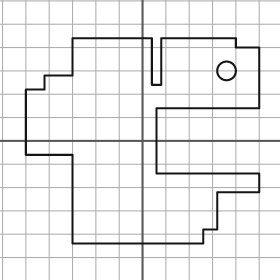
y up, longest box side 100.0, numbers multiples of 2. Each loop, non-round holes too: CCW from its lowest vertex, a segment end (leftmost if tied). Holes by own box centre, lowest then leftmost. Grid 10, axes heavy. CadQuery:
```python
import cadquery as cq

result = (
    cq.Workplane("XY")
    .moveTo(-30.0, -44.0)
    .lineTo(26.0, -44.0)
    .lineTo(26.0, -38.0)
    .lineTo(32.0, -38.0)
    .lineTo(32.0, -22.0)
    .lineTo(50.0, -22.0)
    .lineTo(50.0, -14.0)
    .lineTo(6.0, -14.0)
    .lineTo(6.0, 14.0)
    .lineTo(50.0, 14.0)
    .lineTo(50.0, 40.0)
    .lineTo(40.0, 40.0)
    .lineTo(40.0, 44.0)
    .lineTo(8.0, 44.0)
    .lineTo(8.0, 24.0)
    .lineTo(4.0, 24.0)
    .lineTo(4.0, 44.0)
    .lineTo(-30.0, 44.0)
    .lineTo(-30.0, 28.0)
    .lineTo(-42.0, 28.0)
    .lineTo(-42.0, 22.0)
    .lineTo(-50.0, 22.0)
    .lineTo(-50.0, -6.0)
    .lineTo(-30.0, -6.0)
    .close()
    .moveTo(36.0, 30.0)
    .circle(4.0)
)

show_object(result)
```